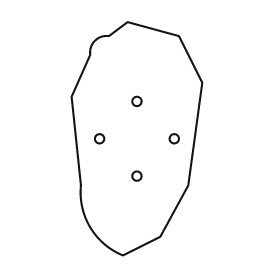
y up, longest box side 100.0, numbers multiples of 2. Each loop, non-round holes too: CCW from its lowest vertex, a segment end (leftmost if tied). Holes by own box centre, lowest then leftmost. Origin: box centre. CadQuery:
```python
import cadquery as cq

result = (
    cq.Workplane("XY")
    .moveTo(-6.0, -50.0)
    .lineTo(10.0, -42.0)
    .lineTo(22.0, -20.0)
    .lineTo(28.0, 24.0)
    .lineTo(18.0, 44.0)
    .lineTo(-4.0, 50.0)
    .lineTo(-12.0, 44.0)
    .threePointArc((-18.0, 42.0), (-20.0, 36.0))
    .lineTo(-28.0, 18.0)
    .lineTo(-24.0, -20.0)
    .threePointArc((-20.0, -38.0), (-6.0, -50.0))
    .close()
    .moveTo(0.0, -16.0)
    .circle(2.0)
    .moveTo(-16.0, 0.0)
    .circle(2.0)
    .moveTo(16.0, 0.0)
    .circle(2.0)
    .moveTo(0.0, 16.0)
    .circle(2.0)
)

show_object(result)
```